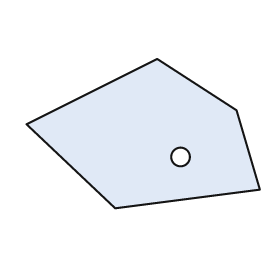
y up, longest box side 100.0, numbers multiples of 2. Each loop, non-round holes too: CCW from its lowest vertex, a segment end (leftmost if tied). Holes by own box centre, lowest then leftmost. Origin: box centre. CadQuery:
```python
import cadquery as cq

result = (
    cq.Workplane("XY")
    .moveTo(-12.0, -32.0)
    .lineTo(50.0, -24.0)
    .lineTo(40.0, 10.0)
    .lineTo(6.0, 32.0)
    .lineTo(-50.0, 4.0)
    .close()
    .moveTo(16.0, -10.0)
    .circle(4.0)
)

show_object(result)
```